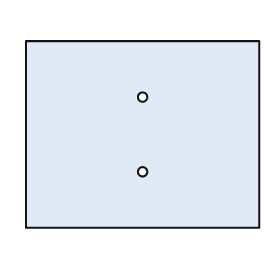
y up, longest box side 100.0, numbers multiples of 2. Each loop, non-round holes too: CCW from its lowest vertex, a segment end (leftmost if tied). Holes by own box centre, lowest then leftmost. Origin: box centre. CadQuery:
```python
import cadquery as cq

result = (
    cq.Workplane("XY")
    .moveTo(-50.0, -40.0)
    .lineTo(50.0, -40.0)
    .lineTo(50.0, 40.0)
    .lineTo(-50.0, 40.0)
    .close()
    .moveTo(0.0, -16.0)
    .circle(2.0)
    .moveTo(0.0, 16.0)
    .circle(2.0)
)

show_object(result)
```